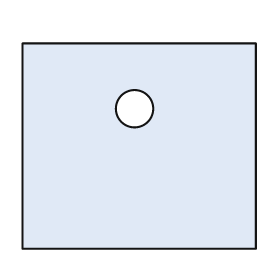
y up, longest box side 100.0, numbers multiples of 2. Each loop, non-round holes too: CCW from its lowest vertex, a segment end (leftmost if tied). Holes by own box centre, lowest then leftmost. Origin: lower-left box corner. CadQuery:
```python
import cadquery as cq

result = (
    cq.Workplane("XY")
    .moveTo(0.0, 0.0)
    .lineTo(100.0, 0.0)
    .lineTo(100.0, 88.0)
    .lineTo(0.0, 88.0)
    .close()
    .moveTo(48.0, 60.0)
    .circle(8.0)
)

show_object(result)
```